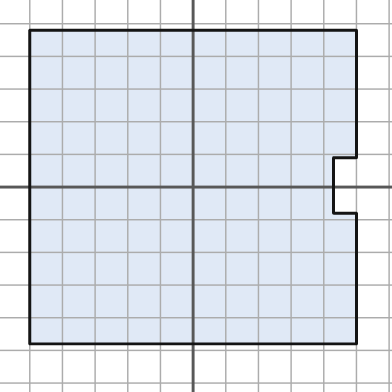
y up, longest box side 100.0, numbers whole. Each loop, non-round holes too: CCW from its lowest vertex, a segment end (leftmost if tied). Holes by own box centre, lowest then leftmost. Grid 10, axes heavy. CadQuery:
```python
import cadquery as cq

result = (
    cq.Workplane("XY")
    .moveTo(-50.0, -48.0)
    .lineTo(50.0, -48.0)
    .lineTo(50.0, -8.0)
    .lineTo(43.0, -8.0)
    .lineTo(43.0, 9.0)
    .lineTo(50.0, 9.0)
    .lineTo(50.0, 48.0)
    .lineTo(-50.0, 48.0)
    .close()
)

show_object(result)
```